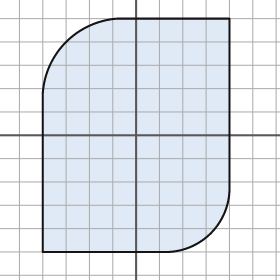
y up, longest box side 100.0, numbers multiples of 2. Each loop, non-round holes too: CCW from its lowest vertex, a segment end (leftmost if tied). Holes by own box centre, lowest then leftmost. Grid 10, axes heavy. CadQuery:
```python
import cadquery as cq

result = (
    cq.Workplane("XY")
    .moveTo(-40.0, -50.0)
    .lineTo(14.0, -50.0)
    .threePointArc((32.0, -42.0), (40.0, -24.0))
    .lineTo(40.0, 50.0)
    .lineTo(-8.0, 50.0)
    .threePointArc((-30.0, 40.0), (-40.0, 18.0))
    .close()
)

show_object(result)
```